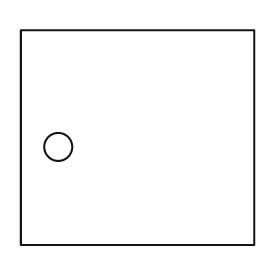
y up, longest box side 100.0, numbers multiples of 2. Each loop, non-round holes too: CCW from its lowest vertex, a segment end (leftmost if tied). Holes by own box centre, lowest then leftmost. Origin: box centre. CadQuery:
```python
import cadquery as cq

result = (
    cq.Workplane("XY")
    .moveTo(-50.0, -46.0)
    .lineTo(50.0, -46.0)
    .lineTo(50.0, 46.0)
    .lineTo(-50.0, 46.0)
    .close()
    .moveTo(-34.0, -4.0)
    .circle(6.0)
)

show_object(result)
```